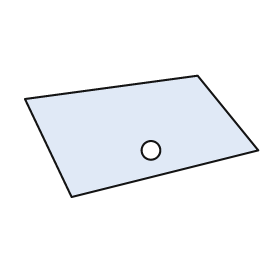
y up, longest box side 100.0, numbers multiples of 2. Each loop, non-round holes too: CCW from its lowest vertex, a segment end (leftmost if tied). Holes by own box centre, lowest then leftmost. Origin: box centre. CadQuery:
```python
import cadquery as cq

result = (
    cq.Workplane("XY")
    .moveTo(-30.0, -26.0)
    .lineTo(50.0, -6.0)
    .lineTo(24.0, 26.0)
    .lineTo(-50.0, 16.0)
    .close()
    .moveTo(4.0, -6.0)
    .circle(4.0)
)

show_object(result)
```